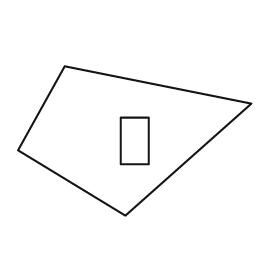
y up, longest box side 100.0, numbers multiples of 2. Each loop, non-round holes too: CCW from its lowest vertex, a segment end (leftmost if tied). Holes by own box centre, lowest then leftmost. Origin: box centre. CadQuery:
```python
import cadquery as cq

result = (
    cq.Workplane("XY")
    .moveTo(-4.0, -32.0)
    .lineTo(50.0, 16.0)
    .lineTo(-30.0, 32.0)
    .lineTo(-50.0, -4.0)
    .close()
    .moveTo(-6.0, -10.0)
    .lineTo(6.0, -10.0)
    .lineTo(6.0, 10.0)
    .lineTo(-6.0, 10.0)
    .close()
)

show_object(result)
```